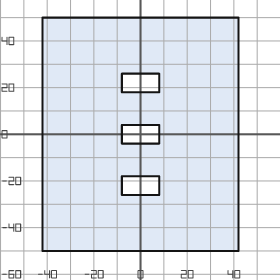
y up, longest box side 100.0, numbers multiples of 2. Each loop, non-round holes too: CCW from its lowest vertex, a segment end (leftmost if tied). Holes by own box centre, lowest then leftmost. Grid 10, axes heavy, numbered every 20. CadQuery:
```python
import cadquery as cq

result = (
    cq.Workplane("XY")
    .moveTo(-42.0, -50.0)
    .lineTo(42.0, -50.0)
    .lineTo(42.0, 50.0)
    .lineTo(-42.0, 50.0)
    .close()
    .moveTo(-8.0, -26.0)
    .lineTo(8.0, -26.0)
    .lineTo(8.0, -18.0)
    .lineTo(-8.0, -18.0)
    .close()
    .moveTo(-8.0, -4.0)
    .lineTo(8.0, -4.0)
    .lineTo(8.0, 4.0)
    .lineTo(-8.0, 4.0)
    .close()
    .moveTo(-8.0, 18.0)
    .lineTo(8.0, 18.0)
    .lineTo(8.0, 26.0)
    .lineTo(-8.0, 26.0)
    .close()
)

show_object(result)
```